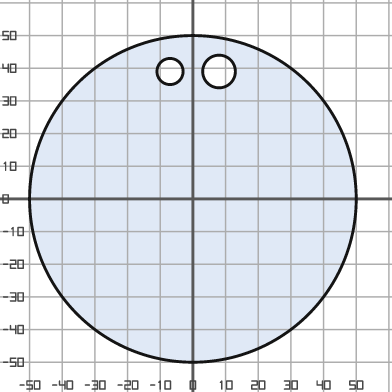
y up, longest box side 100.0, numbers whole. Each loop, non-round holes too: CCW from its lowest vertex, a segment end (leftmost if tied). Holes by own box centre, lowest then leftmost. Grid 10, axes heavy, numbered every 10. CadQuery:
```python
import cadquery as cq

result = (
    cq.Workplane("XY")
    .moveTo(0.0, 0.0)
    .circle(50.0)
    .moveTo(-7.0, 39.0)
    .circle(4.0)
    .moveTo(8.0, 39.0)
    .circle(5.0)
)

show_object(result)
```